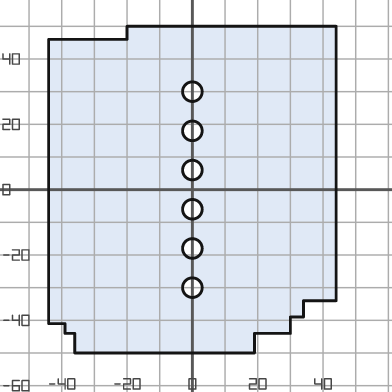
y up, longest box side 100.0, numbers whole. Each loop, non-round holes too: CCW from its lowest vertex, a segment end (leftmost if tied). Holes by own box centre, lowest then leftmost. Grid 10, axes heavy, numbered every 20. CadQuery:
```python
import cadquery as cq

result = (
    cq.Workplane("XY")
    .moveTo(-36.0, -50.0)
    .lineTo(19.0, -50.0)
    .lineTo(19.0, -44.0)
    .lineTo(30.0, -44.0)
    .lineTo(30.0, -39.0)
    .lineTo(34.0, -39.0)
    .lineTo(34.0, -34.0)
    .lineTo(44.0, -34.0)
    .lineTo(44.0, 50.0)
    .lineTo(-20.0, 50.0)
    .lineTo(-20.0, 46.0)
    .lineTo(-44.0, 46.0)
    .lineTo(-44.0, -41.0)
    .lineTo(-39.0, -41.0)
    .lineTo(-39.0, -44.0)
    .lineTo(-36.0, -44.0)
    .close()
    .moveTo(0.0, -30.0)
    .circle(3.0)
    .moveTo(0.0, -18.0)
    .circle(3.0)
    .moveTo(0.0, -6.0)
    .circle(3.0)
    .moveTo(0.0, 6.0)
    .circle(3.0)
    .moveTo(0.0, 18.0)
    .circle(3.0)
    .moveTo(0.0, 30.0)
    .circle(3.0)
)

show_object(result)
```